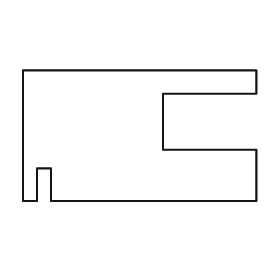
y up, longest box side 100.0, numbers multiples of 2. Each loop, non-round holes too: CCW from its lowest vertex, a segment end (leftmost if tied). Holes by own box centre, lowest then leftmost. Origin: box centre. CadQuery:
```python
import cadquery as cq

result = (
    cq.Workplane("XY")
    .moveTo(-50.0, -28.0)
    .lineTo(-44.0, -28.0)
    .lineTo(-44.0, -14.0)
    .lineTo(-38.0, -14.0)
    .lineTo(-38.0, -28.0)
    .lineTo(50.0, -28.0)
    .lineTo(50.0, -6.0)
    .lineTo(10.0, -6.0)
    .lineTo(10.0, 18.0)
    .lineTo(50.0, 18.0)
    .lineTo(50.0, 28.0)
    .lineTo(-50.0, 28.0)
    .close()
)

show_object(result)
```